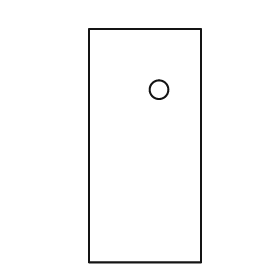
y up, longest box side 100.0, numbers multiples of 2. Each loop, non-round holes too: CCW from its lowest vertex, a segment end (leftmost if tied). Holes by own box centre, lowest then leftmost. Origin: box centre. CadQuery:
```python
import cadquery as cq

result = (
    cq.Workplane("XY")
    .moveTo(-24.0, -50.0)
    .lineTo(24.0, -50.0)
    .lineTo(24.0, 50.0)
    .lineTo(-24.0, 50.0)
    .close()
    .moveTo(6.0, 24.0)
    .circle(4.0)
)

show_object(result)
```